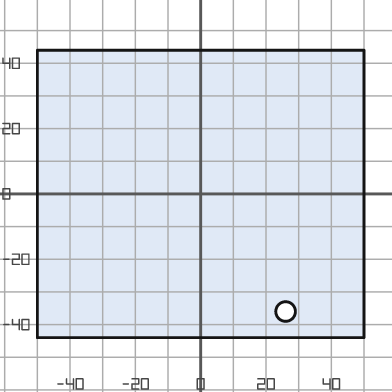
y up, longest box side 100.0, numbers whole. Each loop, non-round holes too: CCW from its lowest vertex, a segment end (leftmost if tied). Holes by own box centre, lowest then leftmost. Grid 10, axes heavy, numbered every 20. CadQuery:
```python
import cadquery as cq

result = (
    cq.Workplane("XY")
    .moveTo(-50.0, -44.0)
    .lineTo(50.0, -44.0)
    .lineTo(50.0, 44.0)
    .lineTo(-50.0, 44.0)
    .close()
    .moveTo(26.0, -36.0)
    .circle(3.0)
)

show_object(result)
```